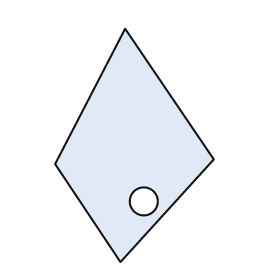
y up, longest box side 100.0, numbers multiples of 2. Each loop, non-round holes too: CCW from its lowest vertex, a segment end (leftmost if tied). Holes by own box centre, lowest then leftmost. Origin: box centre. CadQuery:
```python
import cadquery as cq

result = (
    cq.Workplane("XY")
    .moveTo(-6.0, -50.0)
    .lineTo(34.0, -6.0)
    .lineTo(-4.0, 50.0)
    .lineTo(-34.0, -8.0)
    .close()
    .moveTo(4.0, -24.0)
    .circle(6.0)
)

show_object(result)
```